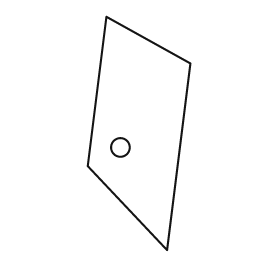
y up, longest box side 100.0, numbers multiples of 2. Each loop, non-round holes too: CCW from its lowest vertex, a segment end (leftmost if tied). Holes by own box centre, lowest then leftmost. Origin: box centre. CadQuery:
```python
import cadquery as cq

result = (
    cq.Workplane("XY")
    .moveTo(12.0, -50.0)
    .lineTo(22.0, 30.0)
    .lineTo(-14.0, 50.0)
    .lineTo(-22.0, -14.0)
    .close()
    .moveTo(-8.0, -6.0)
    .circle(4.0)
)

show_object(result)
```